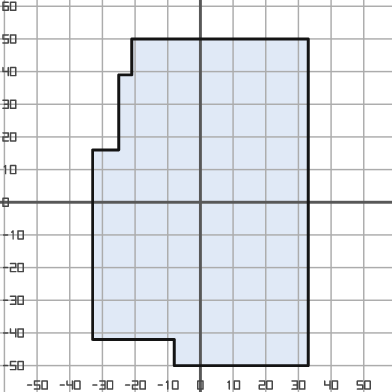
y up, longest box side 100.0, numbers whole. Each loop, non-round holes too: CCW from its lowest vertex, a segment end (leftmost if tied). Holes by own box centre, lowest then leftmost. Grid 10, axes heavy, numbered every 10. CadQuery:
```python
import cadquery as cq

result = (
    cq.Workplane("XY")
    .moveTo(-8.0, -50.0)
    .lineTo(33.0, -50.0)
    .lineTo(33.0, 50.0)
    .lineTo(-21.0, 50.0)
    .lineTo(-21.0, 39.0)
    .lineTo(-25.0, 39.0)
    .lineTo(-25.0, 16.0)
    .lineTo(-33.0, 16.0)
    .lineTo(-33.0, -42.0)
    .lineTo(-8.0, -42.0)
    .close()
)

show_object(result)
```